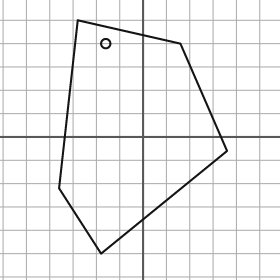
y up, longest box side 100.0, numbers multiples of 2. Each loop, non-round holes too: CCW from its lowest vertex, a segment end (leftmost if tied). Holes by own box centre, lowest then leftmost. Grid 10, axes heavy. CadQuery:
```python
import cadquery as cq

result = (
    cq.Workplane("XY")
    .moveTo(-18.0, -50.0)
    .lineTo(36.0, -6.0)
    .lineTo(16.0, 40.0)
    .lineTo(-28.0, 50.0)
    .lineTo(-36.0, -22.0)
    .close()
    .moveTo(-16.0, 40.0)
    .circle(2.0)
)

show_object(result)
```